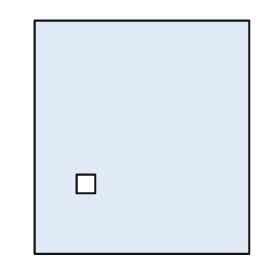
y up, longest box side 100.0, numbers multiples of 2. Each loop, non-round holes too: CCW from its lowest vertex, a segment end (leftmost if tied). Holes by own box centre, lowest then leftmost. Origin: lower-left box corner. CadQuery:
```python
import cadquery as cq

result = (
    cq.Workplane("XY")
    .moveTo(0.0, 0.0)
    .lineTo(92.0, 0.0)
    .lineTo(92.0, 100.0)
    .lineTo(0.0, 100.0)
    .close()
    .moveTo(18.0, 26.0)
    .lineTo(26.0, 26.0)
    .lineTo(26.0, 34.0)
    .lineTo(18.0, 34.0)
    .close()
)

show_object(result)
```